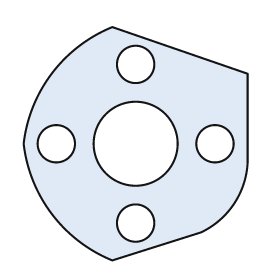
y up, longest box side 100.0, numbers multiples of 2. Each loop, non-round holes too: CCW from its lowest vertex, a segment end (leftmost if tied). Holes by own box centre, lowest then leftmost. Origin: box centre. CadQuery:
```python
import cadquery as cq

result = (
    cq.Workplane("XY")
    .moveTo(-10.0, -50.0)
    .lineTo(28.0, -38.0)
    .threePointArc((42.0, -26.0), (48.0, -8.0))
    .lineTo(48.0, 30.0)
    .lineTo(-10.0, 50.0)
    .threePointArc((-36.0, 30.0), (-48.0, 0.0))
    .threePointArc((-36.0, -30.0), (-10.0, -50.0))
    .close()
    .moveTo(0.0, -34.0)
    .circle(8.0)
    .moveTo(-34.0, 0.0)
    .circle(8.0)
    .moveTo(0.0, 0.0)
    .circle(18.0)
    .moveTo(34.0, 0.0)
    .circle(8.0)
    .moveTo(0.0, 34.0)
    .circle(8.0)
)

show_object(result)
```